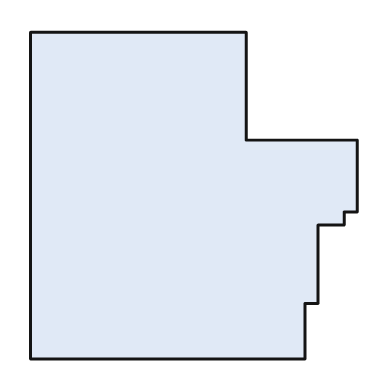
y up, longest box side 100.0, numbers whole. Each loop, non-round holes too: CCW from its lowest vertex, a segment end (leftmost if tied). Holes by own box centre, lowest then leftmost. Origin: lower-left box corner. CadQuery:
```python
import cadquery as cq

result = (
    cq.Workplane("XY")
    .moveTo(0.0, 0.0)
    .lineTo(84.0, 0.0)
    .lineTo(84.0, 17.0)
    .lineTo(88.0, 17.0)
    .lineTo(88.0, 41.0)
    .lineTo(96.0, 41.0)
    .lineTo(96.0, 45.0)
    .lineTo(100.0, 45.0)
    .lineTo(100.0, 67.0)
    .lineTo(66.0, 67.0)
    .lineTo(66.0, 100.0)
    .lineTo(0.0, 100.0)
    .close()
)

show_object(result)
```